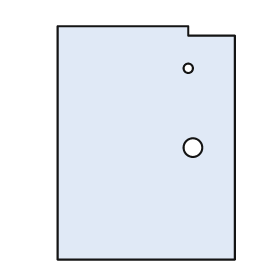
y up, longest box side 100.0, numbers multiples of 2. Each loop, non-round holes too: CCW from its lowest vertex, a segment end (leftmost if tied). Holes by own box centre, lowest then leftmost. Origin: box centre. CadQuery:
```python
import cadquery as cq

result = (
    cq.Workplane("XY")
    .moveTo(-38.0, -50.0)
    .lineTo(38.0, -50.0)
    .lineTo(38.0, 46.0)
    .lineTo(18.0, 46.0)
    .lineTo(18.0, 50.0)
    .lineTo(-38.0, 50.0)
    .close()
    .moveTo(20.0, -2.0)
    .circle(4.0)
    .moveTo(18.0, 32.0)
    .circle(2.0)
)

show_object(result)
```